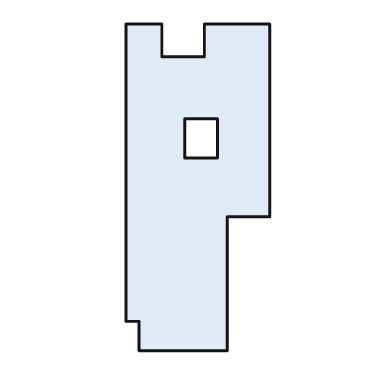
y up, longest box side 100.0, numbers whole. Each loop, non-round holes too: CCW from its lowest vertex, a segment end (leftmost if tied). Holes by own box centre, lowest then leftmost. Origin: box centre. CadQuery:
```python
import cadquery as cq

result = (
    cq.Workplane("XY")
    .moveTo(-18.0, -50.0)
    .lineTo(9.0, -50.0)
    .lineTo(9.0, -9.0)
    .lineTo(22.0, -9.0)
    .lineTo(22.0, 50.0)
    .lineTo(2.0, 50.0)
    .lineTo(2.0, 40.0)
    .lineTo(-11.0, 40.0)
    .lineTo(-11.0, 50.0)
    .lineTo(-22.0, 50.0)
    .lineTo(-22.0, -41.0)
    .lineTo(-18.0, -41.0)
    .close()
    .moveTo(-4.0, 9.0)
    .lineTo(6.0, 9.0)
    .lineTo(6.0, 21.0)
    .lineTo(-4.0, 21.0)
    .close()
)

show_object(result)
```